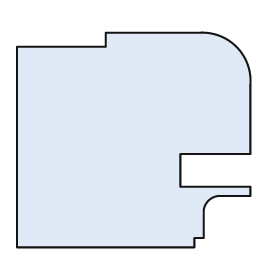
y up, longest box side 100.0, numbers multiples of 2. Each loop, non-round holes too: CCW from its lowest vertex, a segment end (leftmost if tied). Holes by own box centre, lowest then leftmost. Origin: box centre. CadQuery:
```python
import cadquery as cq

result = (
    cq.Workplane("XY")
    .moveTo(-50.0, -46.0)
    .lineTo(26.0, -46.0)
    .lineTo(26.0, -42.0)
    .lineTo(30.0, -42.0)
    .lineTo(30.0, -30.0)
    .threePointArc((32.0, -26.0), (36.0, -24.0))
    .lineTo(50.0, -24.0)
    .lineTo(50.0, -20.0)
    .lineTo(20.0, -20.0)
    .lineTo(20.0, -6.0)
    .lineTo(50.0, -6.0)
    .lineTo(50.0, 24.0)
    .threePointArc((44.0, 40.0), (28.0, 46.0))
    .lineTo(-12.0, 46.0)
    .lineTo(-12.0, 40.0)
    .lineTo(-50.0, 40.0)
    .close()
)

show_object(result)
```